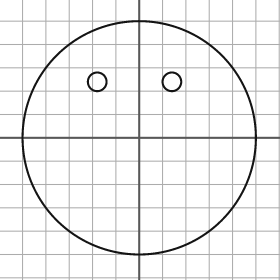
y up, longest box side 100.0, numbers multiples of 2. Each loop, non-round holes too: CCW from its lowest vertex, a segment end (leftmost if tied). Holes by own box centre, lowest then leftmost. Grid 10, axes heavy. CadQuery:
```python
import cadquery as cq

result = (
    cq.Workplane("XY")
    .moveTo(0.0, 0.0)
    .circle(50.0)
    .moveTo(-18.0, 24.0)
    .circle(4.0)
    .moveTo(14.0, 24.0)
    .circle(4.0)
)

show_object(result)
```